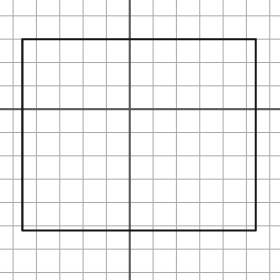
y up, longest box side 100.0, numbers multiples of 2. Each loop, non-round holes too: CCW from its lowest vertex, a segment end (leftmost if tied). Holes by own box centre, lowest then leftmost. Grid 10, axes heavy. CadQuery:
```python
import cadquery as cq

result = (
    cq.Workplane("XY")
    .moveTo(-46.0, -52.0)
    .lineTo(54.0, -52.0)
    .lineTo(54.0, 30.0)
    .lineTo(-46.0, 30.0)
    .close()
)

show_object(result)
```